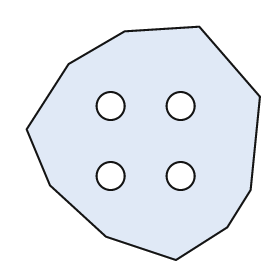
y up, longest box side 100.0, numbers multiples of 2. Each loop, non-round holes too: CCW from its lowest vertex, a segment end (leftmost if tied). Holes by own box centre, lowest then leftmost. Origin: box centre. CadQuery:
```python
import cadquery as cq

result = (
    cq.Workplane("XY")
    .moveTo(14.0, -50.0)
    .lineTo(36.0, -36.0)
    .lineTo(46.0, -20.0)
    .lineTo(50.0, 20.0)
    .lineTo(24.0, 50.0)
    .lineTo(-8.0, 48.0)
    .lineTo(-32.0, 34.0)
    .lineTo(-50.0, 6.0)
    .lineTo(-40.0, -18.0)
    .lineTo(-16.0, -40.0)
    .close()
    .moveTo(-14.0, -14.0)
    .circle(6.0)
    .moveTo(16.0, -14.0)
    .circle(6.0)
    .moveTo(-14.0, 16.0)
    .circle(6.0)
    .moveTo(16.0, 16.0)
    .circle(6.0)
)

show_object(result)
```